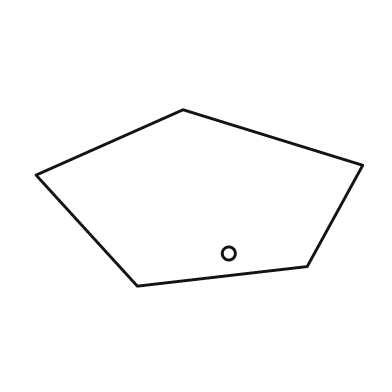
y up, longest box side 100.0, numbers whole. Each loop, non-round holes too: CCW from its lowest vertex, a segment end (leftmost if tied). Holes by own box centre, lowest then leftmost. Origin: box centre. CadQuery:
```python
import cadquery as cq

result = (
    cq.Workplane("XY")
    .moveTo(-19.0, -27.0)
    .lineTo(33.0, -21.0)
    .lineTo(50.0, 10.0)
    .lineTo(-5.0, 27.0)
    .lineTo(-50.0, 7.0)
    .close()
    .moveTo(9.0, -17.0)
    .circle(2.0)
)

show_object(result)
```